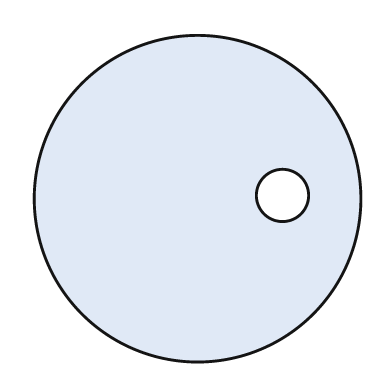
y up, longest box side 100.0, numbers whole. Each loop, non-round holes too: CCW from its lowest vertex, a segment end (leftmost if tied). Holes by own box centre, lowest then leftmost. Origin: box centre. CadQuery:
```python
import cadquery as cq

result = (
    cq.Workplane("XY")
    .moveTo(0.0, 0.0)
    .circle(50.0)
    .moveTo(26.0, 1.0)
    .circle(8.0)
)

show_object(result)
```